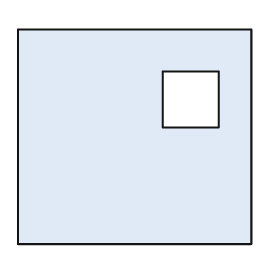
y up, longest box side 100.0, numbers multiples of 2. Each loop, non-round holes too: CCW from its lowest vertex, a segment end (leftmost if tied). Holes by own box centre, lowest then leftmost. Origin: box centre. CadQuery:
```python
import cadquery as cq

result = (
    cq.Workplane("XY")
    .moveTo(-50.0, -46.0)
    .lineTo(50.0, -46.0)
    .lineTo(50.0, 46.0)
    .lineTo(-50.0, 46.0)
    .close()
    .moveTo(12.0, 4.0)
    .lineTo(36.0, 4.0)
    .lineTo(36.0, 28.0)
    .lineTo(12.0, 28.0)
    .close()
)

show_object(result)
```